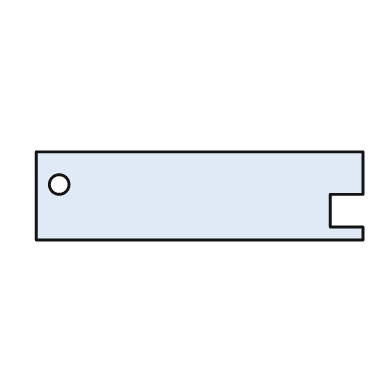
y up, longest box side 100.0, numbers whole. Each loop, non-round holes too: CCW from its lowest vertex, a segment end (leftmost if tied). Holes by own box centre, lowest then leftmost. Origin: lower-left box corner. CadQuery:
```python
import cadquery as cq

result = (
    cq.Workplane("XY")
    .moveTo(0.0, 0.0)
    .lineTo(100.0, 0.0)
    .lineTo(100.0, 4.0)
    .lineTo(90.0, 4.0)
    .lineTo(90.0, 14.0)
    .lineTo(100.0, 14.0)
    .lineTo(100.0, 27.0)
    .lineTo(0.0, 27.0)
    .close()
    .moveTo(7.0, 17.0)
    .circle(3.0)
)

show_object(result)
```